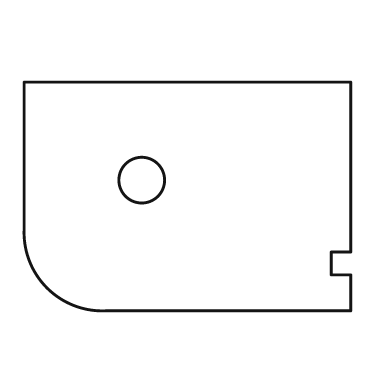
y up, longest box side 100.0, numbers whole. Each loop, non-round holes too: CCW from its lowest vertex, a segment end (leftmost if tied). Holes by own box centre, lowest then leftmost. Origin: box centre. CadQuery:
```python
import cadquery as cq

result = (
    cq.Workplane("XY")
    .moveTo(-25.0, -35.0)
    .lineTo(50.0, -35.0)
    .lineTo(50.0, -24.0)
    .lineTo(44.0, -24.0)
    .lineTo(44.0, -17.0)
    .lineTo(50.0, -17.0)
    .lineTo(50.0, 35.0)
    .lineTo(-50.0, 35.0)
    .lineTo(-50.0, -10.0)
    .threePointArc((-43.0, -28.0), (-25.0, -35.0))
    .close()
    .moveTo(-14.0, 5.0)
    .circle(7.0)
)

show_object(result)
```